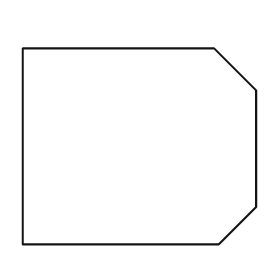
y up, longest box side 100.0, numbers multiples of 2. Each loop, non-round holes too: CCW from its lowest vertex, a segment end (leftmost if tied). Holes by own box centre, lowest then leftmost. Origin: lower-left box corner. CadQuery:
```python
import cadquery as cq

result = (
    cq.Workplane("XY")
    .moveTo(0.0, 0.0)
    .lineTo(84.0, 0.0)
    .lineTo(100.0, 16.0)
    .lineTo(100.0, 66.0)
    .lineTo(82.0, 84.0)
    .lineTo(0.0, 84.0)
    .close()
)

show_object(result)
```